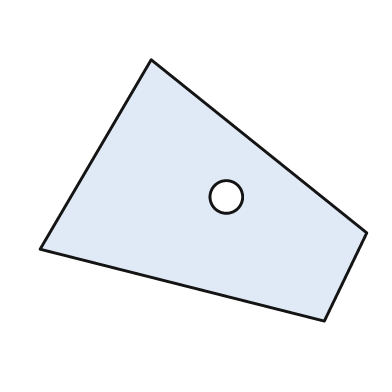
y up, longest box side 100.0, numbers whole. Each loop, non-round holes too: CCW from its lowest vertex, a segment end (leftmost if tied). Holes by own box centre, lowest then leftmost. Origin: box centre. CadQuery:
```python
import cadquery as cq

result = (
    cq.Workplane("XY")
    .moveTo(37.0, -40.0)
    .lineTo(50.0, -13.0)
    .lineTo(-16.0, 40.0)
    .lineTo(-50.0, -18.0)
    .close()
    .moveTo(7.0, -2.0)
    .circle(5.0)
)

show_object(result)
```